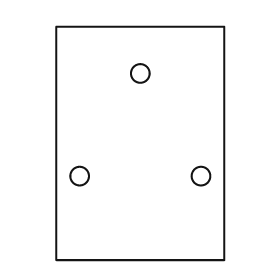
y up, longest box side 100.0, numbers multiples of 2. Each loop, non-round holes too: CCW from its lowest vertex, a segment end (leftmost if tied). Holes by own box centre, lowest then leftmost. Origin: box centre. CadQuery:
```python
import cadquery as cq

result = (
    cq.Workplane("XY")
    .moveTo(-36.0, -50.0)
    .lineTo(36.0, -50.0)
    .lineTo(36.0, 50.0)
    .lineTo(-36.0, 50.0)
    .close()
    .moveTo(-26.0, -14.0)
    .circle(4.0)
    .moveTo(26.0, -14.0)
    .circle(4.0)
    .moveTo(0.0, 30.0)
    .circle(4.0)
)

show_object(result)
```